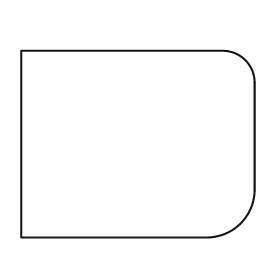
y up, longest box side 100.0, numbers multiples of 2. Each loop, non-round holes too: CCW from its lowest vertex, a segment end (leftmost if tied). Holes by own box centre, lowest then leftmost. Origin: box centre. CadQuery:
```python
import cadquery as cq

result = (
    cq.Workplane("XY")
    .moveTo(-50.0, -40.0)
    .lineTo(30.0, -40.0)
    .threePointArc((44.0, -34.0), (50.0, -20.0))
    .lineTo(50.0, 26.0)
    .threePointArc((46.0, 36.0), (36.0, 40.0))
    .lineTo(-50.0, 40.0)
    .close()
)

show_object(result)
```